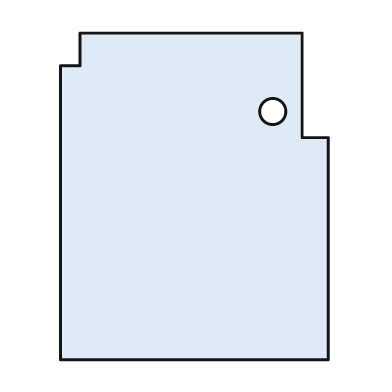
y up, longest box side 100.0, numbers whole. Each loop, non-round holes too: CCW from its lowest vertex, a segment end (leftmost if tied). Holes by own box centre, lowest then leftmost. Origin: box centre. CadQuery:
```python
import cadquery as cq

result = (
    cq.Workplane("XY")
    .moveTo(-41.0, -50.0)
    .lineTo(41.0, -50.0)
    .lineTo(41.0, 18.0)
    .lineTo(33.0, 18.0)
    .lineTo(33.0, 50.0)
    .lineTo(-35.0, 50.0)
    .lineTo(-35.0, 40.0)
    .lineTo(-41.0, 40.0)
    .close()
    .moveTo(24.0, 26.0)
    .circle(4.0)
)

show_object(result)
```